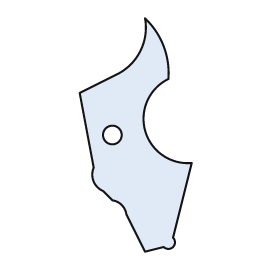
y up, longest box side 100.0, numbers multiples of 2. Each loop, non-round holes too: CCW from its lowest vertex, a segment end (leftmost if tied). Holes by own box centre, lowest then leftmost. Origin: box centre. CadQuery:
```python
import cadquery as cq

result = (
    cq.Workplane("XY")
    .moveTo(4.0, -50.0)
    .lineTo(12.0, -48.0)
    .threePointArc((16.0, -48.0), (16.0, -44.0))
    .lineTo(24.0, -12.0)
    .threePointArc((4.0, 2.0), (14.0, 24.0))
    .threePointArc((12.0, 38.0), (4.0, 50.0))
    .threePointArc((2.0, 36.0), (-8.0, 26.0))
    .lineTo(-24.0, 18.0)
    .lineTo(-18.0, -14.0)
    .threePointArc((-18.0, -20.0), (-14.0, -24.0))
    .lineTo(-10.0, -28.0)
    .threePointArc((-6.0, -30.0), (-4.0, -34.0))
    .close()
    .moveTo(-10.0, 0.0)
    .circle(4.0)
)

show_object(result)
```